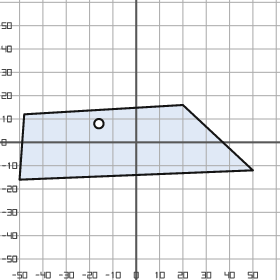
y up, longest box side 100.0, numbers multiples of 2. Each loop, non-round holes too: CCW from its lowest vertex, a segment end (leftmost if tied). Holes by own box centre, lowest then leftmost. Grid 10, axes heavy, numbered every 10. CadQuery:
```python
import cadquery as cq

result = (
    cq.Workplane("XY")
    .moveTo(-50.0, -16.0)
    .lineTo(50.0, -12.0)
    .lineTo(20.0, 16.0)
    .lineTo(-48.0, 12.0)
    .close()
    .moveTo(-16.0, 8.0)
    .circle(2.0)
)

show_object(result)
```